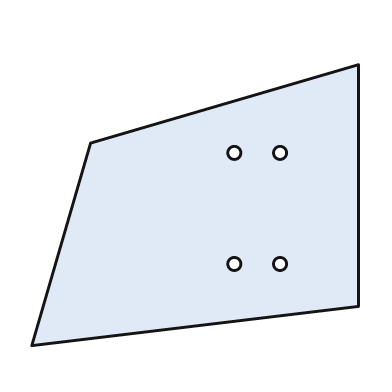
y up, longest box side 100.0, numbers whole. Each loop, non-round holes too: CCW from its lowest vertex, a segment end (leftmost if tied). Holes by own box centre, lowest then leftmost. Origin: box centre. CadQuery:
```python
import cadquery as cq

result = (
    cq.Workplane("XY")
    .moveTo(-50.0, -43.0)
    .lineTo(50.0, -31.0)
    .lineTo(50.0, 43.0)
    .lineTo(-32.0, 19.0)
    .close()
    .moveTo(12.0, -18.0)
    .circle(2.0)
    .moveTo(26.0, -18.0)
    .circle(2.0)
    .moveTo(12.0, 16.0)
    .circle(2.0)
    .moveTo(26.0, 16.0)
    .circle(2.0)
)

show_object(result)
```